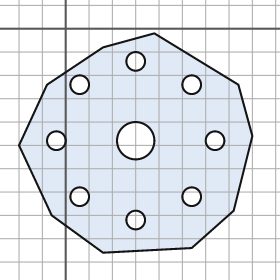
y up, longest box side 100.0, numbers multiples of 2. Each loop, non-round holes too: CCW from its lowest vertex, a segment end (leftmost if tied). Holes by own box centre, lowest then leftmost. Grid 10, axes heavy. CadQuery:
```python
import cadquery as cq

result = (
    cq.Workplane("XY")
    .moveTo(16.0, -96.0)
    .lineTo(54.0, -94.0)
    .lineTo(72.0, -78.0)
    .lineTo(80.0, -46.0)
    .lineTo(74.0, -24.0)
    .lineTo(38.0, -2.0)
    .lineTo(16.0, -8.0)
    .lineTo(-8.0, -24.0)
    .lineTo(-20.0, -50.0)
    .lineTo(-6.0, -80.0)
    .close()
    .moveTo(30.0, -82.0)
    .circle(4.0)
    .moveTo(6.0, -72.0)
    .circle(4.0)
    .moveTo(54.0, -72.0)
    .circle(4.0)
    .moveTo(-4.0, -48.0)
    .circle(4.0)
    .moveTo(30.0, -48.0)
    .circle(8.0)
    .moveTo(64.0, -48.0)
    .circle(4.0)
    .moveTo(6.0, -24.0)
    .circle(4.0)
    .moveTo(54.0, -24.0)
    .circle(4.0)
    .moveTo(30.0, -14.0)
    .circle(4.0)
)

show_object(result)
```